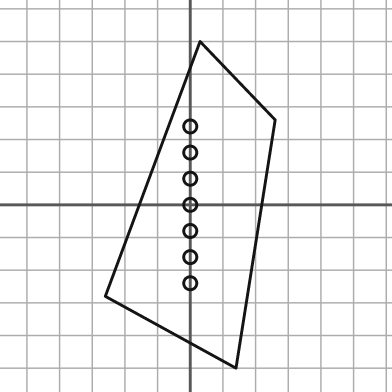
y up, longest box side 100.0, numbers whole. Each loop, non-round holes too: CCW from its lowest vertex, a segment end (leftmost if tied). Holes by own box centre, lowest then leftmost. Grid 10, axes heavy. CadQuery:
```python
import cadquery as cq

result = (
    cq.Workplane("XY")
    .moveTo(14.0, -50.0)
    .lineTo(26.0, 26.0)
    .lineTo(3.0, 50.0)
    .lineTo(-26.0, -28.0)
    .close()
    .moveTo(0.0, -24.0)
    .circle(2.0)
    .moveTo(0.0, -16.0)
    .circle(2.0)
    .moveTo(0.0, -8.0)
    .circle(2.0)
    .moveTo(0.0, 0.0)
    .circle(2.0)
    .moveTo(0.0, 8.0)
    .circle(2.0)
    .moveTo(0.0, 16.0)
    .circle(2.0)
    .moveTo(0.0, 24.0)
    .circle(2.0)
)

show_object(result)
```